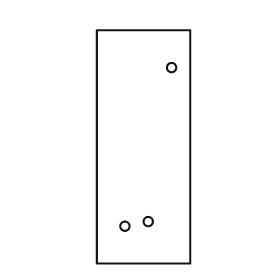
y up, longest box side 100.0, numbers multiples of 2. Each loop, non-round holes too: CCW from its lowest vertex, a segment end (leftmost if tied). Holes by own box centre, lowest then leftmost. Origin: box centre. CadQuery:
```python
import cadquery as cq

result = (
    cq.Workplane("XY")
    .moveTo(-20.0, -50.0)
    .lineTo(20.0, -50.0)
    .lineTo(20.0, 50.0)
    .lineTo(-20.0, 50.0)
    .close()
    .moveTo(-8.0, -34.0)
    .circle(2.0)
    .moveTo(2.0, -32.0)
    .circle(2.0)
    .moveTo(12.0, 34.0)
    .circle(2.0)
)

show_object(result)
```